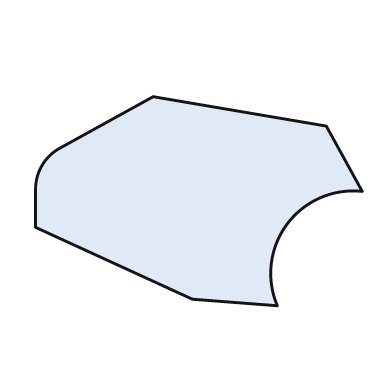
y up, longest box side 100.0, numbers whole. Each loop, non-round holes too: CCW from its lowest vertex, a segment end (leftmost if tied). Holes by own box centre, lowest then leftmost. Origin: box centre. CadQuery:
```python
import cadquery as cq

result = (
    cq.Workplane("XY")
    .moveTo(24.0, -32.0)
    .threePointArc((27.0, -7.0), (50.0, 3.0))
    .lineTo(39.0, 23.0)
    .lineTo(-14.0, 32.0)
    .lineTo(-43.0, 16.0)
    .threePointArc((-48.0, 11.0), (-50.0, 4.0))
    .lineTo(-50.0, -8.0)
    .lineTo(-2.0, -30.0)
    .close()
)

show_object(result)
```